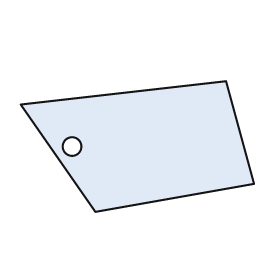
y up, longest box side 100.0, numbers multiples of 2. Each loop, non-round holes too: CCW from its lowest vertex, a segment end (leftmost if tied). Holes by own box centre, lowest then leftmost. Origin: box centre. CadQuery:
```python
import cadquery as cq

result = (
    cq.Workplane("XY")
    .moveTo(-18.0, -28.0)
    .lineTo(50.0, -16.0)
    .lineTo(38.0, 28.0)
    .lineTo(-50.0, 18.0)
    .close()
    .moveTo(-28.0, 0.0)
    .circle(4.0)
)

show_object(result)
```